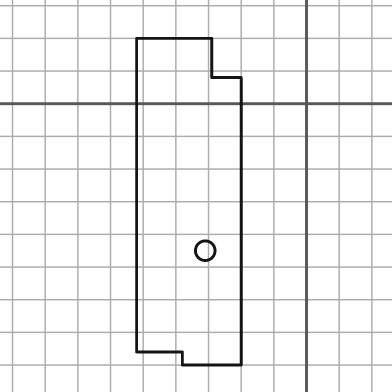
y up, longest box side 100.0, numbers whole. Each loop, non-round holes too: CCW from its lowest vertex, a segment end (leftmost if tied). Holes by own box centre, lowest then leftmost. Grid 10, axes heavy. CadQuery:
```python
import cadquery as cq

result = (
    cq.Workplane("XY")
    .moveTo(-38.0, -80.0)
    .lineTo(-20.0, -80.0)
    .lineTo(-20.0, 8.0)
    .lineTo(-29.0, 8.0)
    .lineTo(-29.0, 20.0)
    .lineTo(-52.0, 20.0)
    .lineTo(-52.0, -76.0)
    .lineTo(-38.0, -76.0)
    .close()
    .moveTo(-31.0, -45.0)
    .circle(3.0)
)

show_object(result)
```